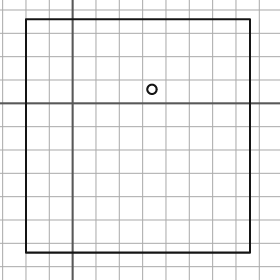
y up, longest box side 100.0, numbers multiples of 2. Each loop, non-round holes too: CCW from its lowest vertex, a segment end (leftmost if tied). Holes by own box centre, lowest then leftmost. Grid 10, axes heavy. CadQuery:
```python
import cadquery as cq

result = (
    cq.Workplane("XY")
    .moveTo(-20.0, -64.0)
    .lineTo(76.0, -64.0)
    .lineTo(76.0, 36.0)
    .lineTo(-20.0, 36.0)
    .close()
    .moveTo(34.0, 6.0)
    .circle(2.0)
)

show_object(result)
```